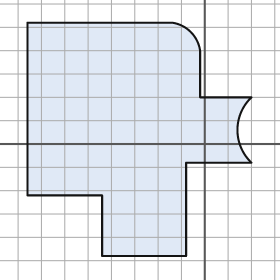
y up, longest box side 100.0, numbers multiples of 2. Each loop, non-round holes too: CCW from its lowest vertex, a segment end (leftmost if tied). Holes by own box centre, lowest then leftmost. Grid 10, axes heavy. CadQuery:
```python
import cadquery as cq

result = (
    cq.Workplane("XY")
    .moveTo(-44.0, -48.0)
    .lineTo(-8.0, -48.0)
    .lineTo(-8.0, -8.0)
    .lineTo(20.0, -8.0)
    .threePointArc((14.0, 6.0), (20.0, 20.0))
    .lineTo(-2.0, 20.0)
    .lineTo(-2.0, 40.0)
    .threePointArc((-6.0, 48.0), (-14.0, 52.0))
    .lineTo(-76.0, 52.0)
    .lineTo(-76.0, -22.0)
    .lineTo(-44.0, -22.0)
    .close()
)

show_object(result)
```